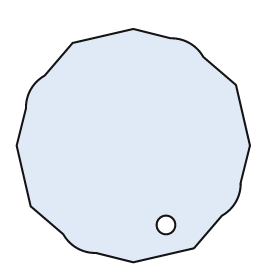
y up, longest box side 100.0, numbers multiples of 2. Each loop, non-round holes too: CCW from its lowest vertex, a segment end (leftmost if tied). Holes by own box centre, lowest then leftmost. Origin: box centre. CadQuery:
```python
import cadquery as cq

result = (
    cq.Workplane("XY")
    .moveTo(0.0, -50.0)
    .lineTo(26.0, -44.0)
    .lineTo(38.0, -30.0)
    .threePointArc((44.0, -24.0), (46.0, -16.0))
    .lineTo(50.0, 0.0)
    .lineTo(44.0, 26.0)
    .lineTo(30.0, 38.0)
    .threePointArc((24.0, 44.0), (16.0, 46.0))
    .lineTo(0.0, 50.0)
    .lineTo(-26.0, 44.0)
    .lineTo(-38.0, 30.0)
    .threePointArc((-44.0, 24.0), (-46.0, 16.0))
    .lineTo(-50.0, 0.0)
    .lineTo(-44.0, -26.0)
    .lineTo(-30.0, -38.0)
    .threePointArc((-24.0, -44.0), (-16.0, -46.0))
    .close()
    .moveTo(14.0, -34.0)
    .circle(4.0)
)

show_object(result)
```